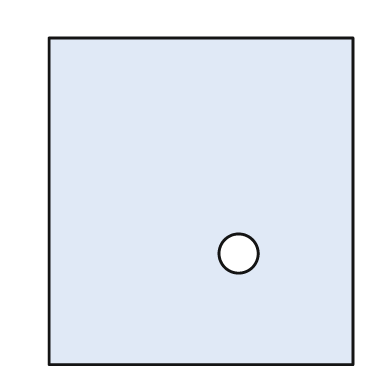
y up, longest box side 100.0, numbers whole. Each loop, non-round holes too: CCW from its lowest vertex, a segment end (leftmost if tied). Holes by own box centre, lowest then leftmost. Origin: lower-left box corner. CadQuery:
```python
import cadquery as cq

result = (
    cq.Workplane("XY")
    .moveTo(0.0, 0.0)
    .lineTo(93.0, 0.0)
    .lineTo(93.0, 100.0)
    .lineTo(0.0, 100.0)
    .close()
    .moveTo(58.0, 34.0)
    .circle(6.0)
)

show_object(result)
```